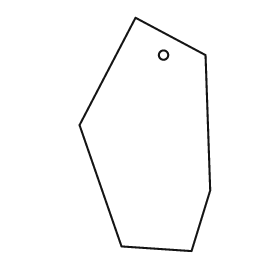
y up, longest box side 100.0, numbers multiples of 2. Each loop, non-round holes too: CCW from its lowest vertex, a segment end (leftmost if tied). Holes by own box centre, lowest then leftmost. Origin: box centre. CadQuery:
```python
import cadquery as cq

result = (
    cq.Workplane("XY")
    .moveTo(20.0, -50.0)
    .lineTo(28.0, -24.0)
    .lineTo(26.0, 34.0)
    .lineTo(-4.0, 50.0)
    .lineTo(-28.0, 4.0)
    .lineTo(-10.0, -48.0)
    .close()
    .moveTo(8.0, 34.0)
    .circle(2.0)
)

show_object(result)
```